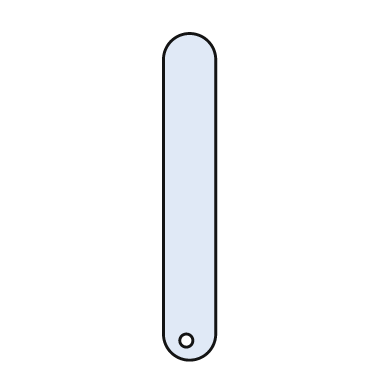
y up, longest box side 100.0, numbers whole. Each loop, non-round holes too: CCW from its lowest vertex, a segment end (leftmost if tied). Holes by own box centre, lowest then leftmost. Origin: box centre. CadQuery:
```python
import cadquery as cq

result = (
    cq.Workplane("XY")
    .moveTo(-8.0, -42.0)
    .threePointArc((0.0, -50.0), (8.0, -42.0))
    .lineTo(8.0, 42.0)
    .threePointArc((0.0, 50.0), (-8.0, 42.0))
    .close()
    .moveTo(-1.0, -44.0)
    .circle(2.0)
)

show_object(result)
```